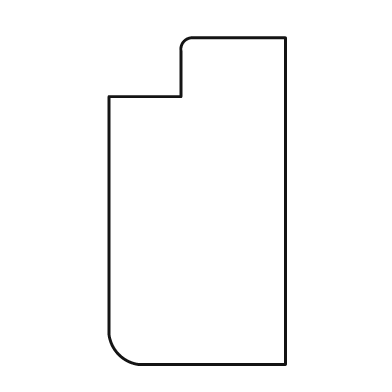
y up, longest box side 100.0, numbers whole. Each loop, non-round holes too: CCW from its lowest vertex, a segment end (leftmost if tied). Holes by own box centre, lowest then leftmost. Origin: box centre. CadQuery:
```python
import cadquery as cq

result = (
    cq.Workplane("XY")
    .moveTo(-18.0, -50.0)
    .lineTo(27.0, -50.0)
    .lineTo(27.0, 50.0)
    .lineTo(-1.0, 50.0)
    .threePointArc((-4.0, 49.0), (-5.0, 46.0))
    .lineTo(-5.0, 32.0)
    .lineTo(-27.0, 32.0)
    .lineTo(-27.0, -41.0)
    .threePointArc((-24.0, -47.0), (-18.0, -50.0))
    .close()
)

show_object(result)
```